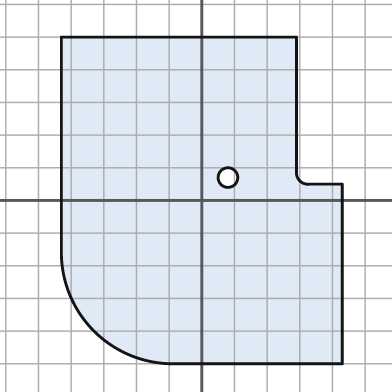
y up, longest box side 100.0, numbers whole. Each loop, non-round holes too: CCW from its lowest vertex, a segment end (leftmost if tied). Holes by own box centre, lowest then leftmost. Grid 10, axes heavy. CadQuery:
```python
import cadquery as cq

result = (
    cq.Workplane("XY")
    .moveTo(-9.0, -50.0)
    .lineTo(43.0, -50.0)
    .lineTo(43.0, 5.0)
    .lineTo(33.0, 5.0)
    .threePointArc((30.0, 6.0), (29.0, 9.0))
    .lineTo(29.0, 50.0)
    .lineTo(-43.0, 50.0)
    .lineTo(-43.0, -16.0)
    .threePointArc((-33.0, -40.0), (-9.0, -50.0))
    .close()
    .moveTo(8.0, 7.0)
    .circle(3.0)
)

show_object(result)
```